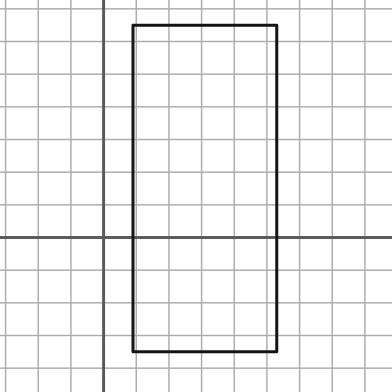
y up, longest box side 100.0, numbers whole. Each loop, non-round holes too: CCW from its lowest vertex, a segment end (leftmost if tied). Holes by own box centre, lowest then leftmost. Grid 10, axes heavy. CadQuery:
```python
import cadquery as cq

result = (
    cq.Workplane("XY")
    .moveTo(9.0, -35.0)
    .lineTo(53.0, -35.0)
    .lineTo(53.0, 65.0)
    .lineTo(9.0, 65.0)
    .close()
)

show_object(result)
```